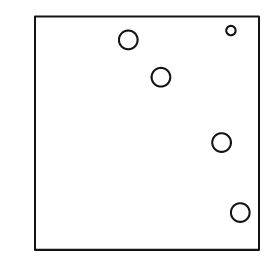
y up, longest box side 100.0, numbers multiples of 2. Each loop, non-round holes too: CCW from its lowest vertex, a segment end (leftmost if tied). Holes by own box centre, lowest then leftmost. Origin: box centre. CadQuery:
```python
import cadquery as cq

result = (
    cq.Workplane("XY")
    .moveTo(-48.0, -50.0)
    .lineTo(48.0, -50.0)
    .lineTo(48.0, 50.0)
    .lineTo(-48.0, 50.0)
    .close()
    .moveTo(40.0, -34.0)
    .circle(4.0)
    .moveTo(32.0, -4.0)
    .circle(4.0)
    .moveTo(6.0, 24.0)
    .circle(4.0)
    .moveTo(-8.0, 40.0)
    .circle(4.0)
    .moveTo(36.0, 44.0)
    .circle(2.0)
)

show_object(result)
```